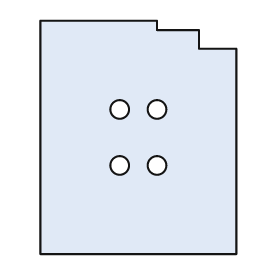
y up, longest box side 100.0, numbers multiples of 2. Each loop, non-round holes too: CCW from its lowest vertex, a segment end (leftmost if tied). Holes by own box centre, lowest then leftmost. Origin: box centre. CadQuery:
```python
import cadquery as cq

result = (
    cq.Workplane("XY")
    .moveTo(-42.0, -50.0)
    .lineTo(42.0, -50.0)
    .lineTo(42.0, 38.0)
    .lineTo(26.0, 38.0)
    .lineTo(26.0, 46.0)
    .lineTo(8.0, 46.0)
    .lineTo(8.0, 50.0)
    .lineTo(-42.0, 50.0)
    .close()
    .moveTo(-8.0, -12.0)
    .circle(4.0)
    .moveTo(8.0, -12.0)
    .circle(4.0)
    .moveTo(-8.0, 12.0)
    .circle(4.0)
    .moveTo(8.0, 12.0)
    .circle(4.0)
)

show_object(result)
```